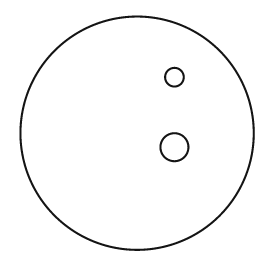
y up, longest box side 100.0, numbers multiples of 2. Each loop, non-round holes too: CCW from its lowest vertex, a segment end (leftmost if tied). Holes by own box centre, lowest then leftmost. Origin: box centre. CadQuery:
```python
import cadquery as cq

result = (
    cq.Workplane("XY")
    .moveTo(0.0, 0.0)
    .circle(50.0)
    .moveTo(16.0, -6.0)
    .circle(6.0)
    .moveTo(16.0, 24.0)
    .circle(4.0)
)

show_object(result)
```